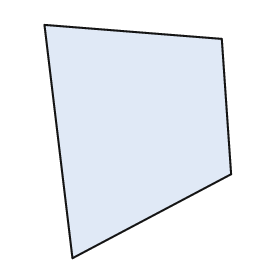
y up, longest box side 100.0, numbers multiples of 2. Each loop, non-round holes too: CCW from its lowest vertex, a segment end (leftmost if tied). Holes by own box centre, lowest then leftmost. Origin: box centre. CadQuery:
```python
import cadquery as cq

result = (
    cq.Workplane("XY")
    .moveTo(-28.0, -50.0)
    .lineTo(40.0, -14.0)
    .lineTo(36.0, 44.0)
    .lineTo(-40.0, 50.0)
    .close()
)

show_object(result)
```